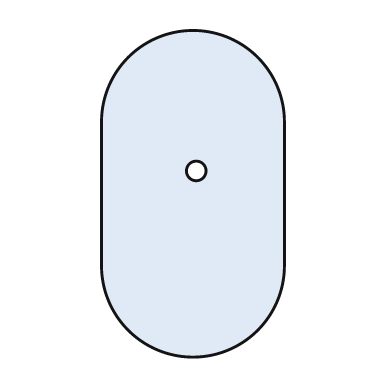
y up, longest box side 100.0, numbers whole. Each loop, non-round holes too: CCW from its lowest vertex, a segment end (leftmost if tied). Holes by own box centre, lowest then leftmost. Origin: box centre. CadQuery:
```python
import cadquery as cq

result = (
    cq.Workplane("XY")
    .moveTo(-28.0, -22.0)
    .threePointArc((0.0, -50.0), (28.0, -22.0))
    .lineTo(28.0, 22.0)
    .threePointArc((0.0, 50.0), (-28.0, 22.0))
    .close()
    .moveTo(1.0, 7.0)
    .circle(3.0)
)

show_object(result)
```